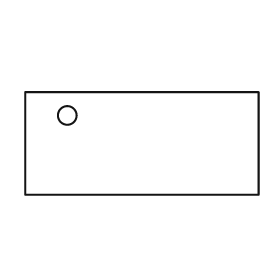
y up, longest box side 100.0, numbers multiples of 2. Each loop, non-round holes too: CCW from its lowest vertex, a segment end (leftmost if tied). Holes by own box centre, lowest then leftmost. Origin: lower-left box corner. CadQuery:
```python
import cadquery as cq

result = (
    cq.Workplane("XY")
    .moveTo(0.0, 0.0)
    .lineTo(100.0, 0.0)
    .lineTo(100.0, 44.0)
    .lineTo(0.0, 44.0)
    .close()
    .moveTo(18.0, 34.0)
    .circle(4.0)
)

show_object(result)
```